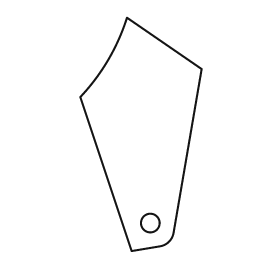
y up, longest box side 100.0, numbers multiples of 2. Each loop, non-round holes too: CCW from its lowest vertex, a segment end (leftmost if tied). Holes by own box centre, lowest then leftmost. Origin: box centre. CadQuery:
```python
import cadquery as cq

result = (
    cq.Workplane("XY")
    .moveTo(-4.0, -50.0)
    .lineTo(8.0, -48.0)
    .threePointArc((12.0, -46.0), (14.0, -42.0))
    .lineTo(26.0, 28.0)
    .lineTo(-6.0, 50.0)
    .threePointArc((-14.0, 32.0), (-26.0, 16.0))
    .close()
    .moveTo(4.0, -38.0)
    .circle(4.0)
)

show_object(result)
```